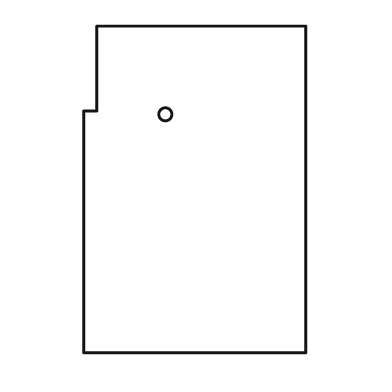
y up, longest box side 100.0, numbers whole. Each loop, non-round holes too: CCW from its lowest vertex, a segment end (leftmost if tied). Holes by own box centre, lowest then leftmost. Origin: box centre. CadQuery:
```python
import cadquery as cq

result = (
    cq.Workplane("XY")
    .moveTo(-34.0, -50.0)
    .lineTo(34.0, -50.0)
    .lineTo(34.0, 50.0)
    .lineTo(-30.0, 50.0)
    .lineTo(-30.0, 24.0)
    .lineTo(-34.0, 24.0)
    .close()
    .moveTo(-9.0, 23.0)
    .circle(2.0)
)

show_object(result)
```